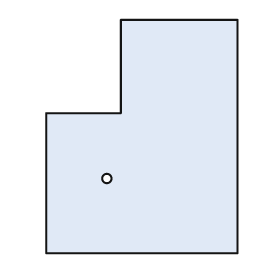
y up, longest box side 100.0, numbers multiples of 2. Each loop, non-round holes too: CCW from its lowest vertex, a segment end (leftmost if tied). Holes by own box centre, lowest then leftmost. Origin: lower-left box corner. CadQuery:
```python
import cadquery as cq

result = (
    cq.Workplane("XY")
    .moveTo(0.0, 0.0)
    .lineTo(82.0, 0.0)
    .lineTo(82.0, 100.0)
    .lineTo(32.0, 100.0)
    .lineTo(32.0, 60.0)
    .lineTo(0.0, 60.0)
    .close()
    .moveTo(26.0, 32.0)
    .circle(2.0)
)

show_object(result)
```